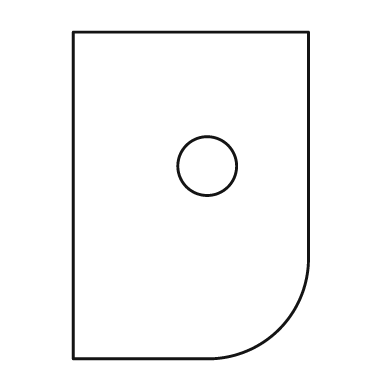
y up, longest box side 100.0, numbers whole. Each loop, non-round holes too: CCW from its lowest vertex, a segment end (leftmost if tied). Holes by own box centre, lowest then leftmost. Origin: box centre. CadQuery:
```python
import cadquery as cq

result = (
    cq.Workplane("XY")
    .moveTo(-36.0, -50.0)
    .lineTo(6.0, -50.0)
    .threePointArc((27.0, -41.0), (36.0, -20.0))
    .lineTo(36.0, 50.0)
    .lineTo(-36.0, 50.0)
    .close()
    .moveTo(5.0, 9.0)
    .circle(9.0)
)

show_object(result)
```